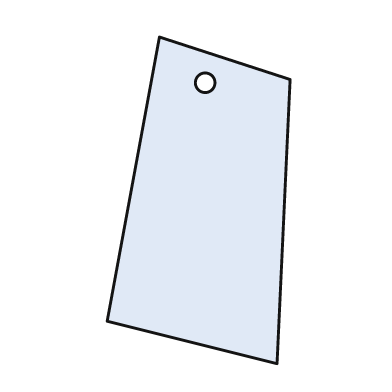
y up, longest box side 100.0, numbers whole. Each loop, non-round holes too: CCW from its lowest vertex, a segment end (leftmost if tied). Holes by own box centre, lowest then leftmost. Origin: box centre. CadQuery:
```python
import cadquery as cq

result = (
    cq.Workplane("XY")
    .moveTo(24.0, -50.0)
    .lineTo(28.0, 37.0)
    .lineTo(-12.0, 50.0)
    .lineTo(-28.0, -37.0)
    .close()
    .moveTo(2.0, 36.0)
    .circle(3.0)
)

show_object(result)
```